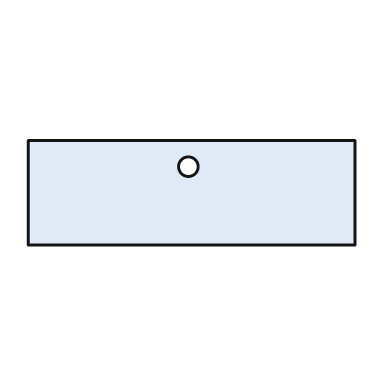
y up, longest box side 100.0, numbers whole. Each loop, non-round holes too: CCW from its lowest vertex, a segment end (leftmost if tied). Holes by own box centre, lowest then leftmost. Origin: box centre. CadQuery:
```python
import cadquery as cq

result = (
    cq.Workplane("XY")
    .moveTo(-50.0, -16.0)
    .lineTo(50.0, -16.0)
    .lineTo(50.0, 16.0)
    .lineTo(-50.0, 16.0)
    .close()
    .moveTo(-1.0, 8.0)
    .circle(3.0)
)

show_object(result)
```